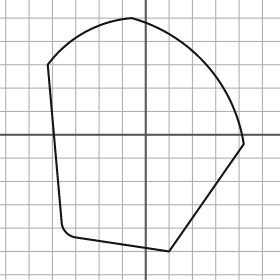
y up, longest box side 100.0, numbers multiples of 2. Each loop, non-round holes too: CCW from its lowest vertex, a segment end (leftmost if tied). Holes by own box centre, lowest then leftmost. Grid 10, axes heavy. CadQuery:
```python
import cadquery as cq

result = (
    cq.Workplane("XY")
    .moveTo(10.0, -50.0)
    .lineTo(42.0, -4.0)
    .threePointArc((26.0, 30.0), (-6.0, 50.0))
    .threePointArc((-26.0, 44.0), (-42.0, 30.0))
    .lineTo(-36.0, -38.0)
    .threePointArc((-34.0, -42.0), (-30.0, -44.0))
    .close()
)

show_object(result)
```